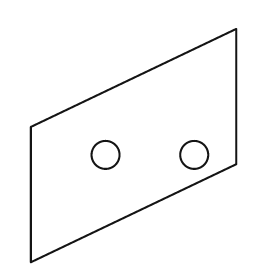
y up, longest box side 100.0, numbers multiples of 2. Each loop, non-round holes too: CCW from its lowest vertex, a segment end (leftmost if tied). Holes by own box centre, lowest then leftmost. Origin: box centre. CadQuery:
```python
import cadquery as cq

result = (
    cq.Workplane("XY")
    .moveTo(-44.0, -50.0)
    .lineTo(44.0, -8.0)
    .lineTo(44.0, 50.0)
    .lineTo(-44.0, 8.0)
    .close()
    .moveTo(-12.0, -4.0)
    .circle(6.0)
    .moveTo(26.0, -4.0)
    .circle(6.0)
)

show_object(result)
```